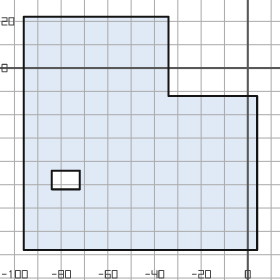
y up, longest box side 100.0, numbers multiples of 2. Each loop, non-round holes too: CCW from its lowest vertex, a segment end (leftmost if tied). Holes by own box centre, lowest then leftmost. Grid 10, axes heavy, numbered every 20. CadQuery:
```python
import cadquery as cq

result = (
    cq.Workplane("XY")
    .moveTo(-96.0, -78.0)
    .lineTo(4.0, -78.0)
    .lineTo(4.0, -12.0)
    .lineTo(-34.0, -12.0)
    .lineTo(-34.0, 22.0)
    .lineTo(-96.0, 22.0)
    .close()
    .moveTo(-84.0, -52.0)
    .lineTo(-72.0, -52.0)
    .lineTo(-72.0, -44.0)
    .lineTo(-84.0, -44.0)
    .close()
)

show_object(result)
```